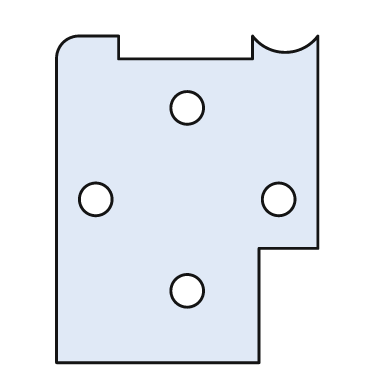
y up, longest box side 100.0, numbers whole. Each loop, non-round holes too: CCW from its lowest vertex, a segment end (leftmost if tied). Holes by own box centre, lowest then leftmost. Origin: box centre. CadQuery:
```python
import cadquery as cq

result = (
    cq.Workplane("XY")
    .moveTo(-40.0, -50.0)
    .lineTo(22.0, -50.0)
    .lineTo(22.0, -15.0)
    .lineTo(40.0, -15.0)
    .lineTo(40.0, 50.0)
    .threePointArc((30.0, 45.0), (20.0, 50.0))
    .lineTo(20.0, 43.0)
    .lineTo(-21.0, 43.0)
    .lineTo(-21.0, 50.0)
    .lineTo(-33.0, 50.0)
    .threePointArc((-38.0, 48.0), (-40.0, 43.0))
    .close()
    .moveTo(0.0, -28.0)
    .circle(5.0)
    .moveTo(-28.0, 0.0)
    .circle(5.0)
    .moveTo(28.0, 0.0)
    .circle(5.0)
    .moveTo(0.0, 28.0)
    .circle(5.0)
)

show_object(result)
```